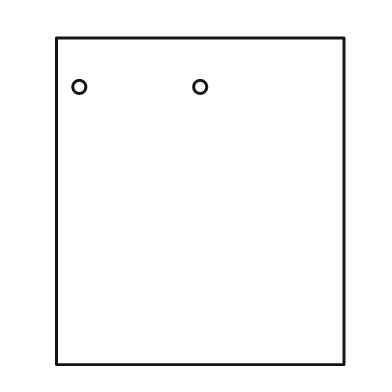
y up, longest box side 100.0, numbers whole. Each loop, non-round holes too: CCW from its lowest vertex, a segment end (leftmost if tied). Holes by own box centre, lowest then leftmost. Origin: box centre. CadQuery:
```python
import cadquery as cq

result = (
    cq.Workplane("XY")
    .moveTo(-44.0, -50.0)
    .lineTo(44.0, -50.0)
    .lineTo(44.0, 50.0)
    .lineTo(-44.0, 50.0)
    .close()
    .moveTo(-37.0, 35.0)
    .circle(2.0)
    .moveTo(0.0, 35.0)
    .circle(2.0)
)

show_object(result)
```